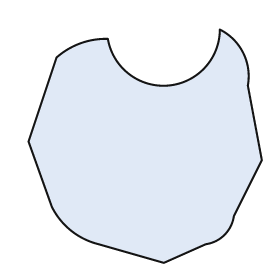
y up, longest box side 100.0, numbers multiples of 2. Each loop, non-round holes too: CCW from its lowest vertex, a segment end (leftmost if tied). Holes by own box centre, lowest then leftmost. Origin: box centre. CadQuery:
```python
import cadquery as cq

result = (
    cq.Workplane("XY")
    .moveTo(8.0, -50.0)
    .lineTo(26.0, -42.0)
    .threePointArc((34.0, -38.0), (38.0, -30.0))
    .lineTo(50.0, -6.0)
    .lineTo(44.0, 26.0)
    .threePointArc((42.0, 40.0), (32.0, 50.0))
    .threePointArc((10.0, 26.0), (-16.0, 46.0))
    .threePointArc((-28.0, 44.0), (-38.0, 38.0))
    .lineTo(-50.0, 2.0)
    .lineTo(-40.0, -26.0)
    .threePointArc((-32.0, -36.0), (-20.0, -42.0))
    .close()
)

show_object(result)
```